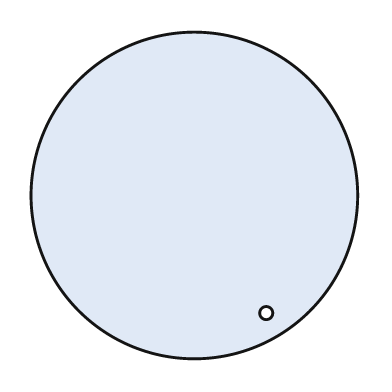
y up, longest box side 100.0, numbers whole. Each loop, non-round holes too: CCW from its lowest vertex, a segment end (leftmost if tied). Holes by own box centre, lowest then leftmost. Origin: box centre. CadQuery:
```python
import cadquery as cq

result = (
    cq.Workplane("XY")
    .moveTo(0.0, 0.0)
    .circle(50.0)
    .moveTo(22.0, -36.0)
    .circle(2.0)
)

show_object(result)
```